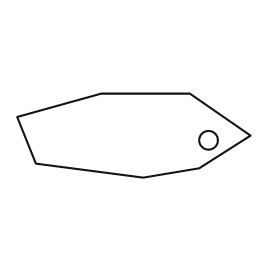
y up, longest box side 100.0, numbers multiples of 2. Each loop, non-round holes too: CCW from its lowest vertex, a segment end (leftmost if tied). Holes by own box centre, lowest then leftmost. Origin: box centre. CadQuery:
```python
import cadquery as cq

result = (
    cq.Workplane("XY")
    .moveTo(4.0, -18.0)
    .lineTo(28.0, -14.0)
    .lineTo(50.0, 0.0)
    .lineTo(24.0, 18.0)
    .lineTo(-14.0, 18.0)
    .lineTo(-50.0, 8.0)
    .lineTo(-42.0, -12.0)
    .close()
    .moveTo(32.0, -2.0)
    .circle(4.0)
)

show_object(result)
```